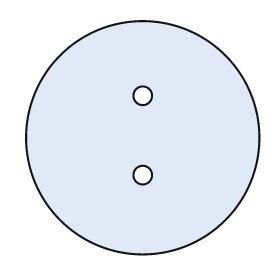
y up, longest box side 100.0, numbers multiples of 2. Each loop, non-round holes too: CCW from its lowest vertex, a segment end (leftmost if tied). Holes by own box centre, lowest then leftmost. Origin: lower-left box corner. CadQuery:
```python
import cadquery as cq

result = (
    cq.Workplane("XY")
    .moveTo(50.0, 50.0)
    .circle(50.0)
    .moveTo(50.0, 34.0)
    .circle(4.0)
    .moveTo(50.0, 68.0)
    .circle(4.0)
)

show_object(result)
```